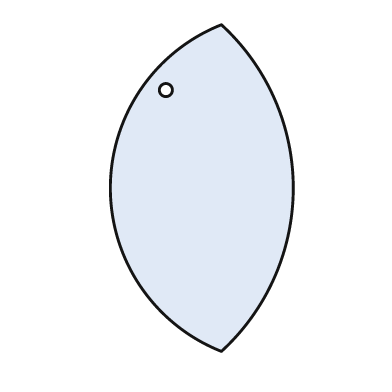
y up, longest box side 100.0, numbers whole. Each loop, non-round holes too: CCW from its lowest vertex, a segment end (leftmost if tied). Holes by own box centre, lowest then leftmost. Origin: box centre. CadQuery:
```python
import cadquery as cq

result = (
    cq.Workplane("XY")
    .moveTo(6.0, -50.0)
    .threePointArc((28.0, 0.0), (6.0, 50.0))
    .threePointArc((-28.0, 0.0), (6.0, -50.0))
    .close()
    .moveTo(-11.0, 30.0)
    .circle(2.0)
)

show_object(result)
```